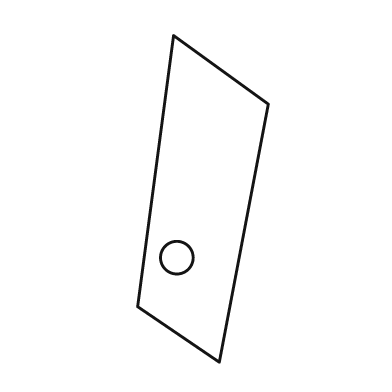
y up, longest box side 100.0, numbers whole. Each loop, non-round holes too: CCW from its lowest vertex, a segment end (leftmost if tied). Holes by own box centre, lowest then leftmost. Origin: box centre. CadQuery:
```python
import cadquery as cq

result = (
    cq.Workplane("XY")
    .moveTo(5.0, -50.0)
    .lineTo(20.0, 29.0)
    .lineTo(-9.0, 50.0)
    .lineTo(-20.0, -33.0)
    .close()
    .moveTo(-8.0, -18.0)
    .circle(5.0)
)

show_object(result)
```